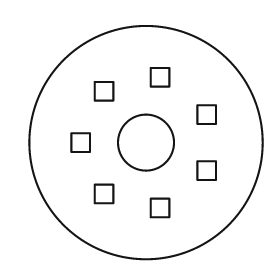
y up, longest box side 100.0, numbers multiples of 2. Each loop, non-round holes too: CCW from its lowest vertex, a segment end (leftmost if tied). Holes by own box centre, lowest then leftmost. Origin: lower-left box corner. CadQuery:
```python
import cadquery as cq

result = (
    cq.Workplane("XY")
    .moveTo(50.0, 50.0)
    .circle(50.0)
    .moveTo(52.0, 18.0)
    .lineTo(60.0, 18.0)
    .lineTo(60.0, 26.0)
    .lineTo(52.0, 26.0)
    .close()
    .moveTo(28.0, 24.0)
    .lineTo(36.0, 24.0)
    .lineTo(36.0, 32.0)
    .lineTo(28.0, 32.0)
    .close()
    .moveTo(72.0, 34.0)
    .lineTo(80.0, 34.0)
    .lineTo(80.0, 42.0)
    .lineTo(72.0, 42.0)
    .close()
    .moveTo(18.0, 46.0)
    .lineTo(26.0, 46.0)
    .lineTo(26.0, 54.0)
    .lineTo(18.0, 54.0)
    .close()
    .moveTo(50.0, 50.0)
    .circle(12.0)
    .moveTo(72.0, 58.0)
    .lineTo(80.0, 58.0)
    .lineTo(80.0, 66.0)
    .lineTo(72.0, 66.0)
    .close()
    .moveTo(28.0, 68.0)
    .lineTo(36.0, 68.0)
    .lineTo(36.0, 76.0)
    .lineTo(28.0, 76.0)
    .close()
    .moveTo(52.0, 74.0)
    .lineTo(60.0, 74.0)
    .lineTo(60.0, 82.0)
    .lineTo(52.0, 82.0)
    .close()
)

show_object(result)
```